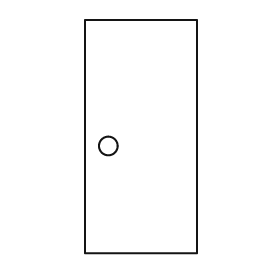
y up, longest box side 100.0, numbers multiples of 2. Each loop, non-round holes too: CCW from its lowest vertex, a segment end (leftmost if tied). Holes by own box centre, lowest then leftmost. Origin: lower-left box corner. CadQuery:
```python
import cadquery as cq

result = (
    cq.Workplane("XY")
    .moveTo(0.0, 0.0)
    .lineTo(48.0, 0.0)
    .lineTo(48.0, 100.0)
    .lineTo(0.0, 100.0)
    .close()
    .moveTo(10.0, 46.0)
    .circle(4.0)
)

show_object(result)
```